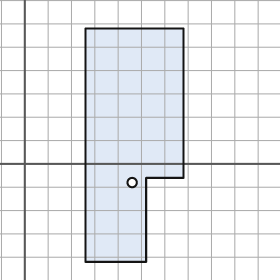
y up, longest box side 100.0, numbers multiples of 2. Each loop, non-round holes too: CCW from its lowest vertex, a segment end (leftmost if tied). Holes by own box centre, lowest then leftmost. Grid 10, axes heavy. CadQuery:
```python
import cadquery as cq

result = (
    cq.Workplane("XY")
    .moveTo(26.0, -42.0)
    .lineTo(52.0, -42.0)
    .lineTo(52.0, -6.0)
    .lineTo(68.0, -6.0)
    .lineTo(68.0, 58.0)
    .lineTo(26.0, 58.0)
    .close()
    .moveTo(46.0, -8.0)
    .circle(2.0)
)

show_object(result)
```